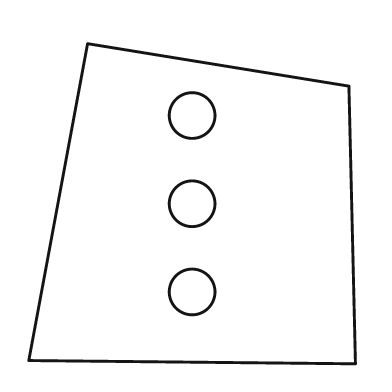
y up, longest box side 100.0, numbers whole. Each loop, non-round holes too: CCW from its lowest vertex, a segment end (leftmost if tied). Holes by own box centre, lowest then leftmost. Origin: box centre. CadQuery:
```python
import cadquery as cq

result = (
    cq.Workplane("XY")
    .moveTo(50.0, -49.0)
    .lineTo(48.0, 36.0)
    .lineTo(-32.0, 49.0)
    .lineTo(-50.0, -48.0)
    .close()
    .moveTo(0.0, -27.0)
    .circle(7.0)
    .moveTo(0.0, 0.0)
    .circle(7.0)
    .moveTo(0.0, 27.0)
    .circle(7.0)
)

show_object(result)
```